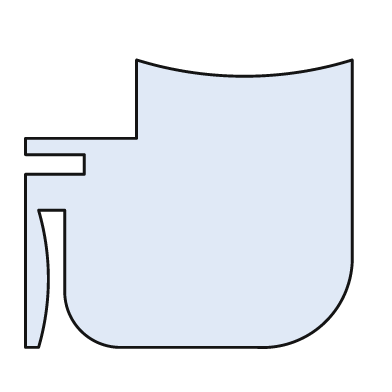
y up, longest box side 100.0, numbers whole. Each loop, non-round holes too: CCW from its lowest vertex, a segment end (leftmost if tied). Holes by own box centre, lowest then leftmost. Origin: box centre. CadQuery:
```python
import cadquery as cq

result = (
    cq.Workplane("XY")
    .moveTo(-50.0, -44.0)
    .lineTo(-46.0, -44.0)
    .threePointArc((-43.0, -23.0), (-46.0, -2.0))
    .lineTo(-38.0, -2.0)
    .lineTo(-38.0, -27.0)
    .threePointArc((-33.0, -39.0), (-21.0, -44.0))
    .lineTo(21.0, -44.0)
    .threePointArc((42.0, -36.0), (50.0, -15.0))
    .lineTo(50.0, 44.0)
    .threePointArc((17.0, 39.0), (-16.0, 44.0))
    .lineTo(-16.0, 20.0)
    .lineTo(-50.0, 20.0)
    .lineTo(-50.0, 15.0)
    .lineTo(-32.0, 15.0)
    .lineTo(-32.0, 9.0)
    .lineTo(-50.0, 9.0)
    .close()
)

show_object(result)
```